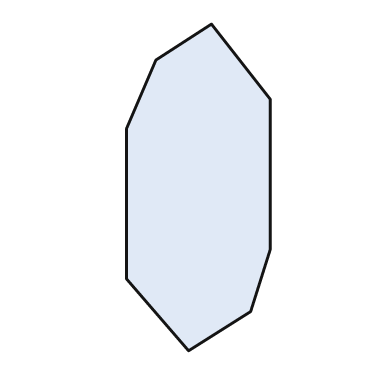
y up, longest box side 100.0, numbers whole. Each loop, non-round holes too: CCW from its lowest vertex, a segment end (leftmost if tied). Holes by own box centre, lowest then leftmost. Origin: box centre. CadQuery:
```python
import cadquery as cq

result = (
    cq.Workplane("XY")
    .moveTo(-3.0, -50.0)
    .lineTo(16.0, -38.0)
    .lineTo(22.0, -19.0)
    .lineTo(22.0, 27.0)
    .lineTo(4.0, 50.0)
    .lineTo(-13.0, 39.0)
    .lineTo(-22.0, 18.0)
    .lineTo(-22.0, -28.0)
    .close()
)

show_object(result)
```